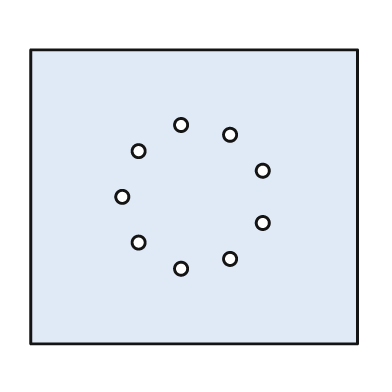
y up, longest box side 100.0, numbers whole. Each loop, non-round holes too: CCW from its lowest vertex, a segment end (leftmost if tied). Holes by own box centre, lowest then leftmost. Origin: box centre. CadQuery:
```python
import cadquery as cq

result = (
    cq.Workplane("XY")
    .moveTo(-50.0, -45.0)
    .lineTo(50.0, -45.0)
    .lineTo(50.0, 45.0)
    .lineTo(-50.0, 45.0)
    .close()
    .moveTo(-4.0, -22.0)
    .circle(2.0)
    .moveTo(11.0, -19.0)
    .circle(2.0)
    .moveTo(-17.0, -14.0)
    .circle(2.0)
    .moveTo(21.0, -8.0)
    .circle(2.0)
    .moveTo(-22.0, 0.0)
    .circle(2.0)
    .moveTo(21.0, 8.0)
    .circle(2.0)
    .moveTo(-17.0, 14.0)
    .circle(2.0)
    .moveTo(11.0, 19.0)
    .circle(2.0)
    .moveTo(-4.0, 22.0)
    .circle(2.0)
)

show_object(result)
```